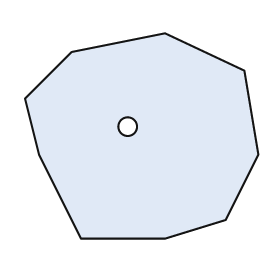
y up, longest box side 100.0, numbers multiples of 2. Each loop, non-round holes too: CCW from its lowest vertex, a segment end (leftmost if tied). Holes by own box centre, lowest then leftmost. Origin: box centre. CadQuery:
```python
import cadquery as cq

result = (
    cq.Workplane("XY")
    .moveTo(-26.0, -44.0)
    .lineTo(10.0, -44.0)
    .lineTo(36.0, -36.0)
    .lineTo(50.0, -8.0)
    .lineTo(44.0, 28.0)
    .lineTo(10.0, 44.0)
    .lineTo(-30.0, 36.0)
    .lineTo(-50.0, 16.0)
    .lineTo(-44.0, -8.0)
    .close()
    .moveTo(-6.0, 4.0)
    .circle(4.0)
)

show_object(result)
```